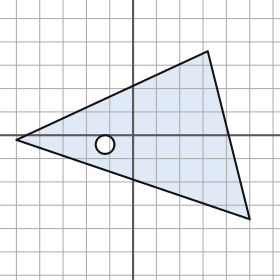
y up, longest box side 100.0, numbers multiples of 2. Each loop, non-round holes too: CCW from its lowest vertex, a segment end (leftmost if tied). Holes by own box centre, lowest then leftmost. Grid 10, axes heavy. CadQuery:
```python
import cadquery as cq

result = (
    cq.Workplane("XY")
    .moveTo(50.0, -36.0)
    .lineTo(32.0, 36.0)
    .lineTo(-50.0, -2.0)
    .close()
    .moveTo(-12.0, -4.0)
    .circle(4.0)
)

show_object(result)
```